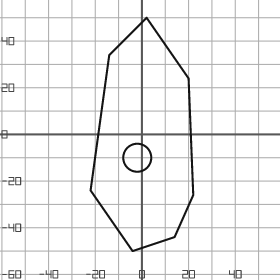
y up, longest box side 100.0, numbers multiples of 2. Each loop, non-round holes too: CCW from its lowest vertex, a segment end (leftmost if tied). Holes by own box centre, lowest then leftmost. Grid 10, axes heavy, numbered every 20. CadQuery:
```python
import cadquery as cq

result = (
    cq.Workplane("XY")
    .moveTo(-4.0, -50.0)
    .lineTo(14.0, -44.0)
    .lineTo(22.0, -26.0)
    .lineTo(20.0, 24.0)
    .lineTo(2.0, 50.0)
    .lineTo(-14.0, 34.0)
    .lineTo(-22.0, -24.0)
    .close()
    .moveTo(-2.0, -10.0)
    .circle(6.0)
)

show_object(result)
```